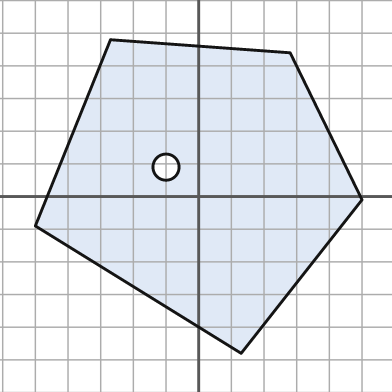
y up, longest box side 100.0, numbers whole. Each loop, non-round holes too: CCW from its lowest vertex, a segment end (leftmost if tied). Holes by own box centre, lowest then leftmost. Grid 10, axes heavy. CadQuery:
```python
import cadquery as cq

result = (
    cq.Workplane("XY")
    .moveTo(13.0, -48.0)
    .lineTo(50.0, -1.0)
    .lineTo(28.0, 44.0)
    .lineTo(-27.0, 48.0)
    .lineTo(-50.0, -9.0)
    .close()
    .moveTo(-10.0, 9.0)
    .circle(4.0)
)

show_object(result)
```